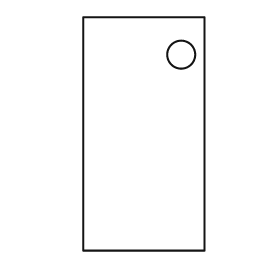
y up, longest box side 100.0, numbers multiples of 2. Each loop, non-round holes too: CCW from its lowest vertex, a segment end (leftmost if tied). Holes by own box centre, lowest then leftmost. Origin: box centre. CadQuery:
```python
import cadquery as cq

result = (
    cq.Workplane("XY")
    .moveTo(-26.0, -50.0)
    .lineTo(26.0, -50.0)
    .lineTo(26.0, 50.0)
    .lineTo(-26.0, 50.0)
    .close()
    .moveTo(16.0, 34.0)
    .circle(6.0)
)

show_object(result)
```